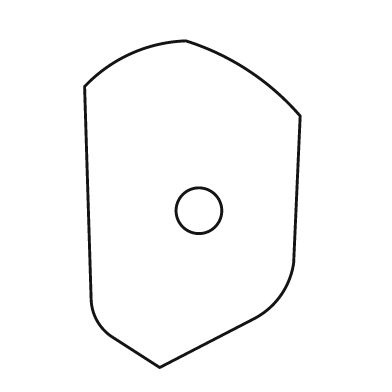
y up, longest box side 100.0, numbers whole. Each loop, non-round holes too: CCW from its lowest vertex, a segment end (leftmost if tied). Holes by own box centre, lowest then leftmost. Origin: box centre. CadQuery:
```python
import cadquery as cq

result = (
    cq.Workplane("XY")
    .moveTo(-10.0, -50.0)
    .lineTo(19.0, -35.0)
    .threePointArc((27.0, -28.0), (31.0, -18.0))
    .lineTo(33.0, 27.0)
    .threePointArc((17.0, 41.0), (-2.0, 50.0))
    .threePointArc((-19.0, 46.0), (-33.0, 36.0))
    .lineTo(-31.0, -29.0)
    .threePointArc((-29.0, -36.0), (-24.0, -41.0))
    .close()
    .moveTo(2.0, -2.0)
    .circle(7.0)
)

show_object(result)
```